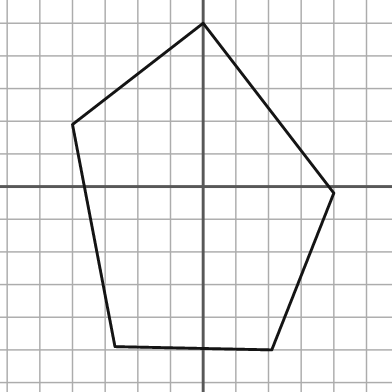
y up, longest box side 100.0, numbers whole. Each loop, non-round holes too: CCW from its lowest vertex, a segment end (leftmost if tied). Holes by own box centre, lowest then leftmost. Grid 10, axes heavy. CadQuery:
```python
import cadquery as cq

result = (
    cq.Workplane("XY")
    .moveTo(21.0, -50.0)
    .lineTo(40.0, -2.0)
    .lineTo(0.0, 50.0)
    .lineTo(-40.0, 19.0)
    .lineTo(-27.0, -49.0)
    .close()
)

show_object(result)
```